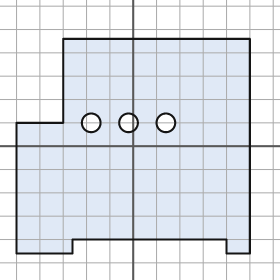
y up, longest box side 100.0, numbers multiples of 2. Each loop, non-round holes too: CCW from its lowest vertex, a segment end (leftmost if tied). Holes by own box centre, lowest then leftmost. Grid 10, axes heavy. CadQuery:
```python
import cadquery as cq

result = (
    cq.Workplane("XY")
    .moveTo(-50.0, -46.0)
    .lineTo(-26.0, -46.0)
    .lineTo(-26.0, -40.0)
    .lineTo(40.0, -40.0)
    .lineTo(40.0, -46.0)
    .lineTo(50.0, -46.0)
    .lineTo(50.0, 46.0)
    .lineTo(-30.0, 46.0)
    .lineTo(-30.0, 10.0)
    .lineTo(-50.0, 10.0)
    .close()
    .moveTo(-18.0, 10.0)
    .circle(4.0)
    .moveTo(-2.0, 10.0)
    .circle(4.0)
    .moveTo(14.0, 10.0)
    .circle(4.0)
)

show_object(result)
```